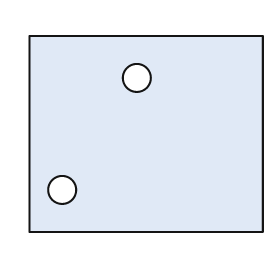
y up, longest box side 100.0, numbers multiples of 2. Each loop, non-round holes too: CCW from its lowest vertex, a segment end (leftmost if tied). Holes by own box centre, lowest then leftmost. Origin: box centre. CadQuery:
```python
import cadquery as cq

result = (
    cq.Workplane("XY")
    .moveTo(-50.0, -42.0)
    .lineTo(50.0, -42.0)
    .lineTo(50.0, 42.0)
    .lineTo(-50.0, 42.0)
    .close()
    .moveTo(-36.0, -24.0)
    .circle(6.0)
    .moveTo(-4.0, 24.0)
    .circle(6.0)
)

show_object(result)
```